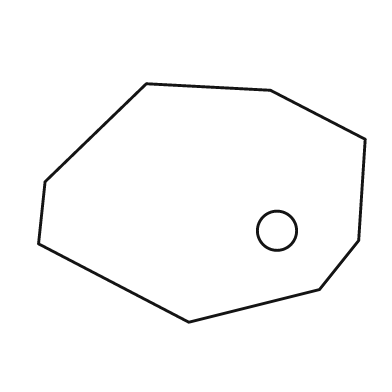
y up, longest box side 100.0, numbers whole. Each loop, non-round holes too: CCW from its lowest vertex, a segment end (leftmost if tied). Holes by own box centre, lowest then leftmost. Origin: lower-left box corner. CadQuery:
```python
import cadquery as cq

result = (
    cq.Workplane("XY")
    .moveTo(46.0, 0.0)
    .lineTo(86.0, 10.0)
    .lineTo(98.0, 25.0)
    .lineTo(100.0, 56.0)
    .lineTo(71.0, 71.0)
    .lineTo(33.0, 73.0)
    .lineTo(2.0, 43.0)
    .lineTo(0.0, 24.0)
    .close()
    .moveTo(73.0, 28.0)
    .circle(6.0)
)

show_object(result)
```